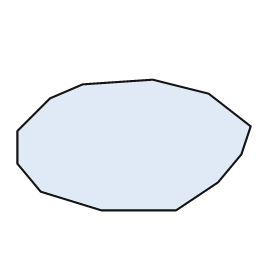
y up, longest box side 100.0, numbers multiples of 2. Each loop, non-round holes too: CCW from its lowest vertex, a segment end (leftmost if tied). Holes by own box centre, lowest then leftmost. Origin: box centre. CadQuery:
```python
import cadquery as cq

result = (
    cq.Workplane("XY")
    .moveTo(-14.0, -28.0)
    .lineTo(18.0, -28.0)
    .lineTo(36.0, -16.0)
    .lineTo(46.0, -4.0)
    .lineTo(50.0, 8.0)
    .lineTo(32.0, 22.0)
    .lineTo(8.0, 28.0)
    .lineTo(-22.0, 26.0)
    .lineTo(-36.0, 20.0)
    .lineTo(-50.0, 6.0)
    .lineTo(-50.0, -8.0)
    .lineTo(-40.0, -20.0)
    .close()
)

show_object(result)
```